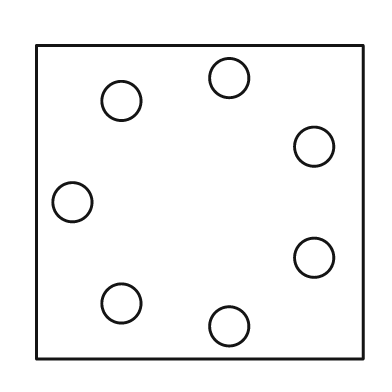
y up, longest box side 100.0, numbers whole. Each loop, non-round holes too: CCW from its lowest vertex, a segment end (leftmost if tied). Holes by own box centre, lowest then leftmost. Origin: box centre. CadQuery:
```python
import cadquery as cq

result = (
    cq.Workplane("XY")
    .moveTo(-50.0, -48.0)
    .lineTo(50.0, -48.0)
    .lineTo(50.0, 48.0)
    .lineTo(-50.0, 48.0)
    .close()
    .moveTo(9.0, -38.0)
    .circle(6.0)
    .moveTo(-24.0, -31.0)
    .circle(6.0)
    .moveTo(35.0, -17.0)
    .circle(6.0)
    .moveTo(-39.0, 0.0)
    .circle(6.0)
    .moveTo(35.0, 17.0)
    .circle(6.0)
    .moveTo(-24.0, 31.0)
    .circle(6.0)
    .moveTo(9.0, 38.0)
    .circle(6.0)
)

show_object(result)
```